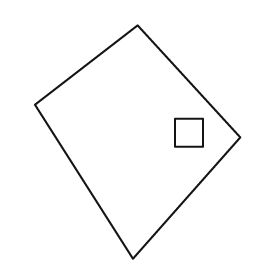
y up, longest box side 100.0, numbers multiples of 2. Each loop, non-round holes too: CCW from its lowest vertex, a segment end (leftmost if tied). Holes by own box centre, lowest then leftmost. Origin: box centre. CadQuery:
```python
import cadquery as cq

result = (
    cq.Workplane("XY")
    .moveTo(-2.0, -50.0)
    .lineTo(44.0, 2.0)
    .lineTo(0.0, 50.0)
    .lineTo(-44.0, 16.0)
    .close()
    .moveTo(16.0, -2.0)
    .lineTo(28.0, -2.0)
    .lineTo(28.0, 10.0)
    .lineTo(16.0, 10.0)
    .close()
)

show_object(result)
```